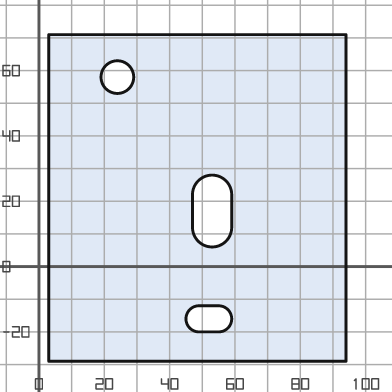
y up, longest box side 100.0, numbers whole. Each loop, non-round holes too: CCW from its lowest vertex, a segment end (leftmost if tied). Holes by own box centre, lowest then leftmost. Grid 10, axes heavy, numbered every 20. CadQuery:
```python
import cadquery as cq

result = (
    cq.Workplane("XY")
    .moveTo(3.0, -29.0)
    .lineTo(94.0, -29.0)
    .lineTo(94.0, 71.0)
    .lineTo(3.0, 71.0)
    .close()
    .moveTo(49.0, -20.0)
    .lineTo(55.0, -20.0)
    .threePointArc((59.0, -16.0), (55.0, -12.0))
    .lineTo(49.0, -12.0)
    .threePointArc((45.0, -16.0), (49.0, -20.0))
    .close()
    .moveTo(47.0, 12.0)
    .threePointArc((53.0, 6.0), (59.0, 12.0))
    .lineTo(59.0, 22.0)
    .threePointArc((53.0, 28.0), (47.0, 22.0))
    .close()
    .moveTo(24.0, 58.0)
    .circle(5.0)
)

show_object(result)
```